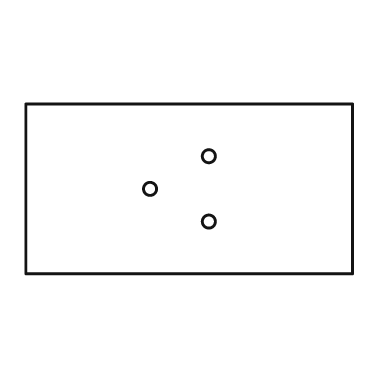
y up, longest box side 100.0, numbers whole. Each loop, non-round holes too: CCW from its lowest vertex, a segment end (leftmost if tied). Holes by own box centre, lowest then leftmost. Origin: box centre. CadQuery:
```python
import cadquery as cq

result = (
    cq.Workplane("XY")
    .moveTo(-50.0, -26.0)
    .lineTo(50.0, -26.0)
    .lineTo(50.0, 26.0)
    .lineTo(-50.0, 26.0)
    .close()
    .moveTo(6.0, -10.0)
    .circle(2.0)
    .moveTo(-12.0, 0.0)
    .circle(2.0)
    .moveTo(6.0, 10.0)
    .circle(2.0)
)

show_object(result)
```